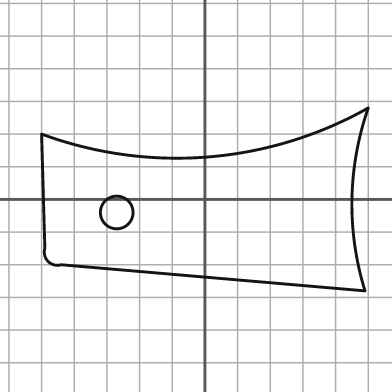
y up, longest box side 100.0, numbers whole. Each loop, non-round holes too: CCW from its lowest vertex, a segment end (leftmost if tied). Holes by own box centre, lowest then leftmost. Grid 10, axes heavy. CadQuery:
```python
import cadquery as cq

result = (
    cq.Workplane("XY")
    .moveTo(49.0, -28.0)
    .threePointArc((45.0, 0.0), (50.0, 28.0))
    .threePointArc((1.0, 13.0), (-50.0, 20.0))
    .lineTo(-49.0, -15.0)
    .threePointArc((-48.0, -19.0), (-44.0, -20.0))
    .close()
    .moveTo(-27.0, -4.0)
    .circle(5.0)
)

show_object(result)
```